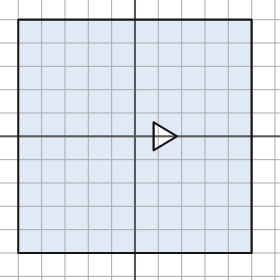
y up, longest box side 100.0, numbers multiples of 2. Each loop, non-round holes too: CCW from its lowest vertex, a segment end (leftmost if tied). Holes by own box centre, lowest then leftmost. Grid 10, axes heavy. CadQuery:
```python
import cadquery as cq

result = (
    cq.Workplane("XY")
    .moveTo(-50.0, -50.0)
    .lineTo(50.0, -50.0)
    .lineTo(50.0, 50.0)
    .lineTo(-50.0, 50.0)
    .close()
    .moveTo(8.0, -6.0)
    .lineTo(18.0, 0.0)
    .lineTo(8.0, 6.0)
    .close()
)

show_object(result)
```